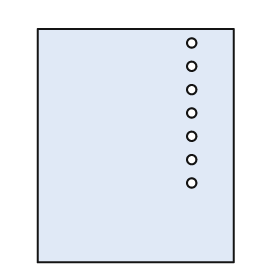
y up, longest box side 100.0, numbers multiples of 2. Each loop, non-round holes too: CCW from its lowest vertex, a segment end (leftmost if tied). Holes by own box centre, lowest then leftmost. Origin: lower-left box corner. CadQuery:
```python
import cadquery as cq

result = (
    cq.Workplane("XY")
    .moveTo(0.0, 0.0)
    .lineTo(84.0, 0.0)
    .lineTo(84.0, 100.0)
    .lineTo(0.0, 100.0)
    .close()
    .moveTo(66.0, 34.0)
    .circle(2.0)
    .moveTo(66.0, 44.0)
    .circle(2.0)
    .moveTo(66.0, 54.0)
    .circle(2.0)
    .moveTo(66.0, 64.0)
    .circle(2.0)
    .moveTo(66.0, 74.0)
    .circle(2.0)
    .moveTo(66.0, 84.0)
    .circle(2.0)
    .moveTo(66.0, 94.0)
    .circle(2.0)
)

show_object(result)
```